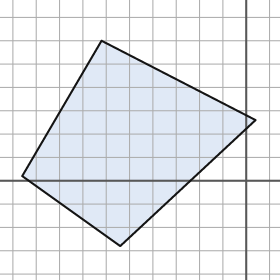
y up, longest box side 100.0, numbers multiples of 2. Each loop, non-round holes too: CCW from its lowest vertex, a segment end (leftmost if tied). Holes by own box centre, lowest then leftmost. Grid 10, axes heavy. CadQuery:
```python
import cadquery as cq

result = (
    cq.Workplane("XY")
    .moveTo(-54.0, -28.0)
    .lineTo(4.0, 26.0)
    .lineTo(-62.0, 60.0)
    .lineTo(-96.0, 2.0)
    .close()
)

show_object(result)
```